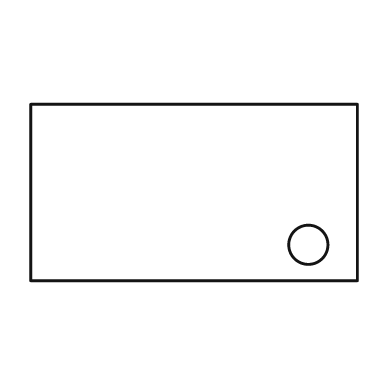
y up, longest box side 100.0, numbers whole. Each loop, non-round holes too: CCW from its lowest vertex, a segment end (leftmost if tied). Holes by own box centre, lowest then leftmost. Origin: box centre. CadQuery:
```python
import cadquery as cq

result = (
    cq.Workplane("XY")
    .moveTo(-50.0, -27.0)
    .lineTo(50.0, -27.0)
    .lineTo(50.0, 27.0)
    .lineTo(-50.0, 27.0)
    .close()
    .moveTo(35.0, -16.0)
    .circle(6.0)
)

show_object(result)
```